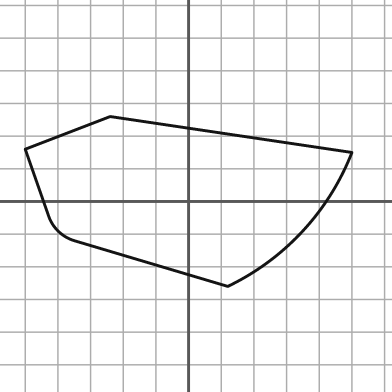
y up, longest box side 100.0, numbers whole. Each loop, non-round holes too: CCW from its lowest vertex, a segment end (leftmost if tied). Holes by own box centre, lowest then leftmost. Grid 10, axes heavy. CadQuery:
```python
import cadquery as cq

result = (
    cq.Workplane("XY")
    .moveTo(12.0, -26.0)
    .threePointArc((35.0, -9.0), (50.0, 15.0))
    .lineTo(-24.0, 26.0)
    .lineTo(-50.0, 16.0)
    .lineTo(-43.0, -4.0)
    .threePointArc((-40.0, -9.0), (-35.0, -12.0))
    .close()
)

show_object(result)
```